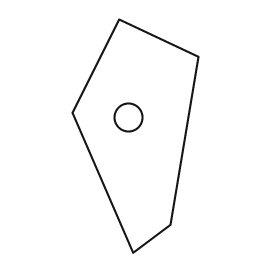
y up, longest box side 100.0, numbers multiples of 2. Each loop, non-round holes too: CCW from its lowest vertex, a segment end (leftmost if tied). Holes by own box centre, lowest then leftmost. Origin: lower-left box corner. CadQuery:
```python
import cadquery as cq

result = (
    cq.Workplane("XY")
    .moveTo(26.0, 0.0)
    .lineTo(42.0, 12.0)
    .lineTo(54.0, 84.0)
    .lineTo(20.0, 100.0)
    .lineTo(0.0, 60.0)
    .close()
    .moveTo(24.0, 58.0)
    .circle(6.0)
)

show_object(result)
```